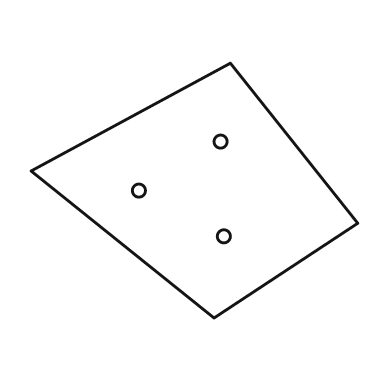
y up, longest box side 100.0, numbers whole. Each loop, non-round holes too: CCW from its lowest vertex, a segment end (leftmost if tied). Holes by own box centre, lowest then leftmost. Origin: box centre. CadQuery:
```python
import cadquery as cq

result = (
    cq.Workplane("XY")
    .moveTo(6.0, -39.0)
    .lineTo(50.0, -10.0)
    .lineTo(11.0, 39.0)
    .lineTo(-50.0, 6.0)
    .close()
    .moveTo(9.0, -14.0)
    .circle(2.0)
    .moveTo(-17.0, 0.0)
    .circle(2.0)
    .moveTo(8.0, 15.0)
    .circle(2.0)
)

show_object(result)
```